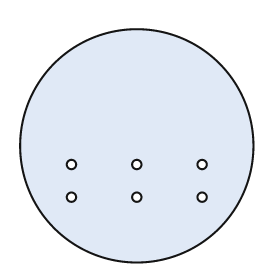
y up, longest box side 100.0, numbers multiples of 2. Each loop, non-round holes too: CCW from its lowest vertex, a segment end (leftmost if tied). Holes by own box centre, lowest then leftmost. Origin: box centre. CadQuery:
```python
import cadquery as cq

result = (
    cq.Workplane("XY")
    .moveTo(0.0, 0.0)
    .circle(50.0)
    .moveTo(-28.0, -22.0)
    .circle(2.0)
    .moveTo(0.0, -22.0)
    .circle(2.0)
    .moveTo(28.0, -22.0)
    .circle(2.0)
    .moveTo(-28.0, -8.0)
    .circle(2.0)
    .moveTo(0.0, -8.0)
    .circle(2.0)
    .moveTo(28.0, -8.0)
    .circle(2.0)
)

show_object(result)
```